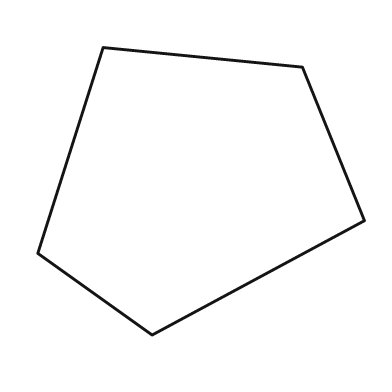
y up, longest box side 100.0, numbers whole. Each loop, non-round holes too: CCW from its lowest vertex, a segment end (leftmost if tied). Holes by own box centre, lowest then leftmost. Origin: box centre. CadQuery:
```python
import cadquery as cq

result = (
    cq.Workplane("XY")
    .moveTo(-15.0, -44.0)
    .lineTo(50.0, -9.0)
    .lineTo(31.0, 38.0)
    .lineTo(-30.0, 44.0)
    .lineTo(-50.0, -19.0)
    .close()
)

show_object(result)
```